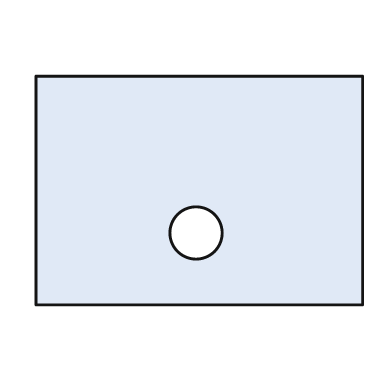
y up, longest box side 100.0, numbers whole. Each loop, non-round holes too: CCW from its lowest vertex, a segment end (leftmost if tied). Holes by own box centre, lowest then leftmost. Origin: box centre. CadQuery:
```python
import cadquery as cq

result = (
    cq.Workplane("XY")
    .moveTo(-50.0, -35.0)
    .lineTo(50.0, -35.0)
    .lineTo(50.0, 35.0)
    .lineTo(-50.0, 35.0)
    .close()
    .moveTo(-1.0, -13.0)
    .circle(8.0)
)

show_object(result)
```